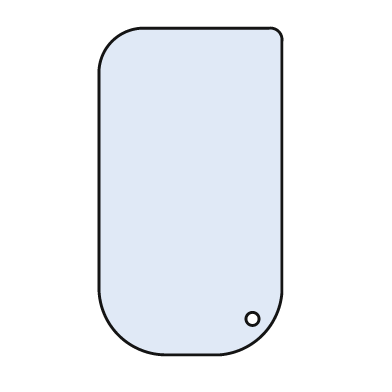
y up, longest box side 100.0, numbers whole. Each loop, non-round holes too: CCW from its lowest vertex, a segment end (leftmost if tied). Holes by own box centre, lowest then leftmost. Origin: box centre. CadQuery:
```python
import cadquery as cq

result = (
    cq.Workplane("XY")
    .moveTo(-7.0, -50.0)
    .lineTo(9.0, -50.0)
    .threePointArc((22.0, -44.0), (28.0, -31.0))
    .lineTo(28.0, 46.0)
    .threePointArc((27.0, 49.0), (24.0, 50.0))
    .lineTo(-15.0, 50.0)
    .threePointArc((-24.0, 46.0), (-28.0, 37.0))
    .lineTo(-28.0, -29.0)
    .threePointArc((-22.0, -44.0), (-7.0, -50.0))
    .close()
    .moveTo(19.0, -39.0)
    .circle(2.0)
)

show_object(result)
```